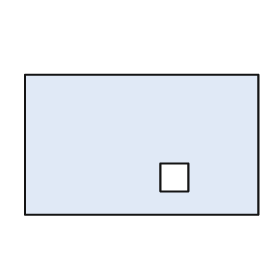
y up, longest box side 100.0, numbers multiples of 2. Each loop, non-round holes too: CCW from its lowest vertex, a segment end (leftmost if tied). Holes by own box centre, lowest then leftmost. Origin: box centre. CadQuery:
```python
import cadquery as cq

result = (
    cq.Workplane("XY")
    .moveTo(-50.0, -30.0)
    .lineTo(50.0, -30.0)
    .lineTo(50.0, 30.0)
    .lineTo(-50.0, 30.0)
    .close()
    .moveTo(8.0, -20.0)
    .lineTo(20.0, -20.0)
    .lineTo(20.0, -8.0)
    .lineTo(8.0, -8.0)
    .close()
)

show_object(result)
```